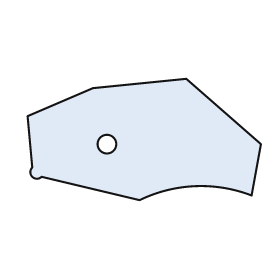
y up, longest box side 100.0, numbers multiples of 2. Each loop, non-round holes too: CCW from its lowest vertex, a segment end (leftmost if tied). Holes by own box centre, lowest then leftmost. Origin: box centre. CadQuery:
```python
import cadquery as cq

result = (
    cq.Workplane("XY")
    .moveTo(-2.0, -26.0)
    .threePointArc((22.0, -20.0), (46.0, -24.0))
    .lineTo(50.0, -2.0)
    .lineTo(18.0, 26.0)
    .lineTo(-22.0, 22.0)
    .lineTo(-50.0, 10.0)
    .lineTo(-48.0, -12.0)
    .threePointArc((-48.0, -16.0), (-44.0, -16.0))
    .close()
    .moveTo(-16.0, -2.0)
    .circle(4.0)
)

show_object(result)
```